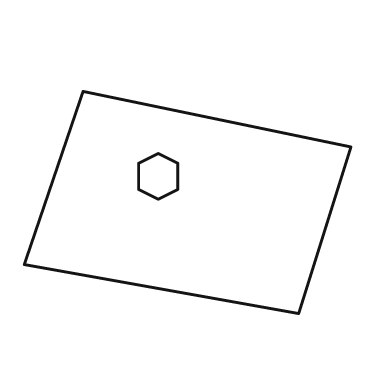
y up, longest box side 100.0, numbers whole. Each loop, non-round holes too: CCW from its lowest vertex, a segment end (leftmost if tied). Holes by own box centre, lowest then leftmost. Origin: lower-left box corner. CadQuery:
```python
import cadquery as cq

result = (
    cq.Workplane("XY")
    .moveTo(84.0, 0.0)
    .lineTo(100.0, 51.0)
    .lineTo(18.0, 68.0)
    .lineTo(0.0, 15.0)
    .close()
    .moveTo(41.0, 35.0)
    .lineTo(47.0, 38.0)
    .lineTo(47.0, 46.0)
    .lineTo(41.0, 49.0)
    .lineTo(35.0, 46.0)
    .lineTo(35.0, 38.0)
    .close()
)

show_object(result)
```